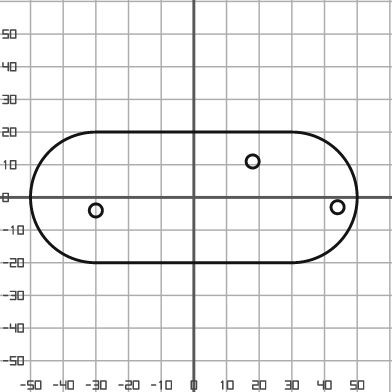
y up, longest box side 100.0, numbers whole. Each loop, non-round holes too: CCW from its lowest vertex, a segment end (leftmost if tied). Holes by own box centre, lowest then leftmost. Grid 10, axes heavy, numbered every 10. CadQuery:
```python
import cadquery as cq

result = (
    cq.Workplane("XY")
    .moveTo(-30.0, -20.0)
    .lineTo(30.0, -20.0)
    .threePointArc((50.0, 0.0), (30.0, 20.0))
    .lineTo(-30.0, 20.0)
    .threePointArc((-50.0, 0.0), (-30.0, -20.0))
    .close()
    .moveTo(-30.0, -4.0)
    .circle(2.0)
    .moveTo(44.0, -3.0)
    .circle(2.0)
    .moveTo(18.0, 11.0)
    .circle(2.0)
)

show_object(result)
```